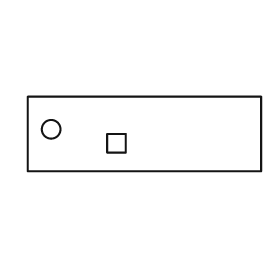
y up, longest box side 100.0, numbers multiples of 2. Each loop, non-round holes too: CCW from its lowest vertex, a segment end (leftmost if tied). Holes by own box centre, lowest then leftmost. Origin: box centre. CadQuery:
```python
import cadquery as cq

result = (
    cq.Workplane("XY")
    .moveTo(-50.0, -16.0)
    .lineTo(50.0, -16.0)
    .lineTo(50.0, 16.0)
    .lineTo(-50.0, 16.0)
    .close()
    .moveTo(-16.0, -8.0)
    .lineTo(-8.0, -8.0)
    .lineTo(-8.0, 0.0)
    .lineTo(-16.0, 0.0)
    .close()
    .moveTo(-40.0, 2.0)
    .circle(4.0)
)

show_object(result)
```